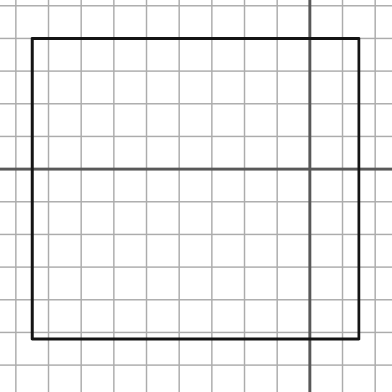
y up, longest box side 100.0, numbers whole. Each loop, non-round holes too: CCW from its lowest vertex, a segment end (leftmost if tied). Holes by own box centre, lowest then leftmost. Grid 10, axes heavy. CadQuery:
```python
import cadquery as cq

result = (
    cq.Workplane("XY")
    .moveTo(-85.0, -52.0)
    .lineTo(15.0, -52.0)
    .lineTo(15.0, 40.0)
    .lineTo(-85.0, 40.0)
    .close()
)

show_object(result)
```